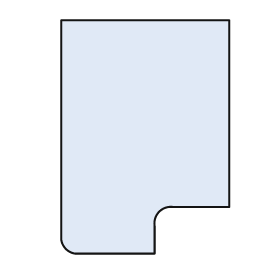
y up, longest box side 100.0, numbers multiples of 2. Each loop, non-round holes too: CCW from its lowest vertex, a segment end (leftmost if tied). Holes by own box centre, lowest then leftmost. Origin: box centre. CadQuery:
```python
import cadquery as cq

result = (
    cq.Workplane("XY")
    .moveTo(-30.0, -50.0)
    .lineTo(4.0, -50.0)
    .lineTo(4.0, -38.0)
    .threePointArc((6.0, -32.0), (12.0, -30.0))
    .lineTo(36.0, -30.0)
    .lineTo(36.0, 50.0)
    .lineTo(-36.0, 50.0)
    .lineTo(-36.0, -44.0)
    .threePointArc((-34.0, -48.0), (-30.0, -50.0))
    .close()
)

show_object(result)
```